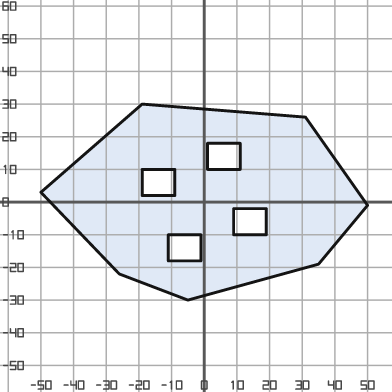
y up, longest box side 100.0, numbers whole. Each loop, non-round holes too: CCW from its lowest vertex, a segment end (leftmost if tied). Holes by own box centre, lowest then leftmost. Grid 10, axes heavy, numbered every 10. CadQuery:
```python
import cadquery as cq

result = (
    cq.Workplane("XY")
    .moveTo(-5.0, -30.0)
    .lineTo(35.0, -19.0)
    .lineTo(50.0, -1.0)
    .lineTo(31.0, 26.0)
    .lineTo(-19.0, 30.0)
    .lineTo(-50.0, 3.0)
    .lineTo(-26.0, -22.0)
    .close()
    .moveTo(-11.0, -18.0)
    .lineTo(-1.0, -18.0)
    .lineTo(-1.0, -10.0)
    .lineTo(-11.0, -10.0)
    .close()
    .moveTo(9.0, -10.0)
    .lineTo(19.0, -10.0)
    .lineTo(19.0, -2.0)
    .lineTo(9.0, -2.0)
    .close()
    .moveTo(-19.0, 2.0)
    .lineTo(-9.0, 2.0)
    .lineTo(-9.0, 10.0)
    .lineTo(-19.0, 10.0)
    .close()
    .moveTo(1.0, 10.0)
    .lineTo(11.0, 10.0)
    .lineTo(11.0, 18.0)
    .lineTo(1.0, 18.0)
    .close()
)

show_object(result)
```